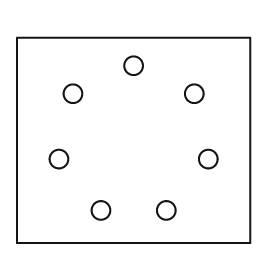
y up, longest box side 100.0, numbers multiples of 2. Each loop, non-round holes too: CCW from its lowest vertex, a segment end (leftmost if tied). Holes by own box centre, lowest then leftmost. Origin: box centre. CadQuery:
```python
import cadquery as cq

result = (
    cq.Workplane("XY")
    .moveTo(-50.0, -44.0)
    .lineTo(50.0, -44.0)
    .lineTo(50.0, 44.0)
    .lineTo(-50.0, 44.0)
    .close()
    .moveTo(-14.0, -30.0)
    .circle(4.0)
    .moveTo(14.0, -30.0)
    .circle(4.0)
    .moveTo(-32.0, -8.0)
    .circle(4.0)
    .moveTo(32.0, -8.0)
    .circle(4.0)
    .moveTo(-26.0, 20.0)
    .circle(4.0)
    .moveTo(26.0, 20.0)
    .circle(4.0)
    .moveTo(0.0, 32.0)
    .circle(4.0)
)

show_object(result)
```